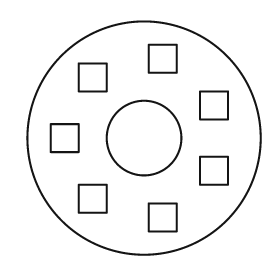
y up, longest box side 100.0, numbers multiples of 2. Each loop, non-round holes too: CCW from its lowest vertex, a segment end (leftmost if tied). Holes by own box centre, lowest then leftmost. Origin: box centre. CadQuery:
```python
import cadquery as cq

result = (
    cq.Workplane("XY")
    .moveTo(0.0, 0.0)
    .circle(50.0)
    .moveTo(2.0, -40.0)
    .lineTo(14.0, -40.0)
    .lineTo(14.0, -28.0)
    .lineTo(2.0, -28.0)
    .close()
    .moveTo(-28.0, -32.0)
    .lineTo(-16.0, -32.0)
    .lineTo(-16.0, -20.0)
    .lineTo(-28.0, -20.0)
    .close()
    .moveTo(24.0, -20.0)
    .lineTo(36.0, -20.0)
    .lineTo(36.0, -8.0)
    .lineTo(24.0, -8.0)
    .close()
    .moveTo(-40.0, -6.0)
    .lineTo(-28.0, -6.0)
    .lineTo(-28.0, 6.0)
    .lineTo(-40.0, 6.0)
    .close()
    .moveTo(0.0, 0.0)
    .circle(16.0)
    .moveTo(24.0, 8.0)
    .lineTo(36.0, 8.0)
    .lineTo(36.0, 20.0)
    .lineTo(24.0, 20.0)
    .close()
    .moveTo(-28.0, 20.0)
    .lineTo(-16.0, 20.0)
    .lineTo(-16.0, 32.0)
    .lineTo(-28.0, 32.0)
    .close()
    .moveTo(2.0, 28.0)
    .lineTo(14.0, 28.0)
    .lineTo(14.0, 40.0)
    .lineTo(2.0, 40.0)
    .close()
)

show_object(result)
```